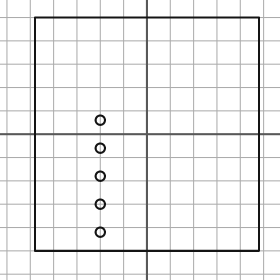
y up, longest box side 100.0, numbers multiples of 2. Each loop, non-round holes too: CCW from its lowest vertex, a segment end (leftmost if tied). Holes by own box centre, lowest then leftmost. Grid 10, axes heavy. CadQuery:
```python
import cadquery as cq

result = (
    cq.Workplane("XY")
    .moveTo(-48.0, -50.0)
    .lineTo(48.0, -50.0)
    .lineTo(48.0, 50.0)
    .lineTo(-48.0, 50.0)
    .close()
    .moveTo(-20.0, -42.0)
    .circle(2.0)
    .moveTo(-20.0, -30.0)
    .circle(2.0)
    .moveTo(-20.0, -18.0)
    .circle(2.0)
    .moveTo(-20.0, -6.0)
    .circle(2.0)
    .moveTo(-20.0, 6.0)
    .circle(2.0)
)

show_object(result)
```